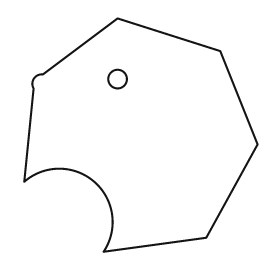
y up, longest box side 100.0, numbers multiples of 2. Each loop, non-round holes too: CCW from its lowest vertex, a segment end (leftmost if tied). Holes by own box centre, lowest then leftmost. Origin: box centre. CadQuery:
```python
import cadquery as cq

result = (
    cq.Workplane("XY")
    .moveTo(-16.0, -50.0)
    .lineTo(28.0, -44.0)
    .lineTo(50.0, -4.0)
    .lineTo(34.0, 36.0)
    .lineTo(-10.0, 50.0)
    .lineTo(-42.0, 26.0)
    .threePointArc((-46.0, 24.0), (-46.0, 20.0))
    .lineTo(-50.0, -20.0)
    .threePointArc((-20.0, -20.0), (-16.0, -50.0))
    .close()
    .moveTo(-10.0, 24.0)
    .circle(4.0)
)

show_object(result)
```